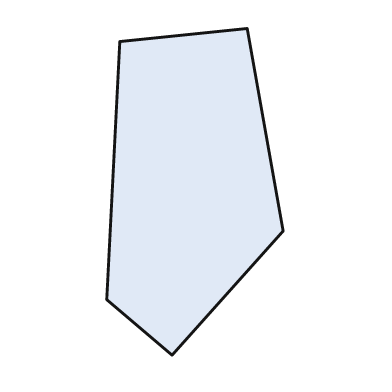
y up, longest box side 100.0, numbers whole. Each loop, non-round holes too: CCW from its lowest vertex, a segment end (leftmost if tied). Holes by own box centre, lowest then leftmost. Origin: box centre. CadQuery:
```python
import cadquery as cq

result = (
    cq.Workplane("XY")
    .moveTo(-7.0, -50.0)
    .lineTo(27.0, -12.0)
    .lineTo(16.0, 50.0)
    .lineTo(-23.0, 46.0)
    .lineTo(-27.0, -33.0)
    .close()
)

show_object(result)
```